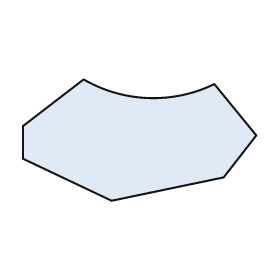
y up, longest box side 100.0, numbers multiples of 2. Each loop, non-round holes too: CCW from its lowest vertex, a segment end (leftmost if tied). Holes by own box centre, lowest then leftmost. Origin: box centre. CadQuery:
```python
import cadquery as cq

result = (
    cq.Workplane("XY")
    .moveTo(-12.0, -26.0)
    .lineTo(36.0, -16.0)
    .lineTo(50.0, 2.0)
    .lineTo(32.0, 24.0)
    .threePointArc((4.0, 18.0), (-24.0, 26.0))
    .lineTo(-50.0, 6.0)
    .lineTo(-50.0, -8.0)
    .close()
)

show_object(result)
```